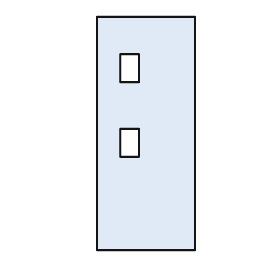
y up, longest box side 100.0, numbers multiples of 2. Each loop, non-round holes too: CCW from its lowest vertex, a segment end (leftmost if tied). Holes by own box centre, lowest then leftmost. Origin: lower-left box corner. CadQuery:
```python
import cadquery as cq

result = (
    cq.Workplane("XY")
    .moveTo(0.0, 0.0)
    .lineTo(42.0, 0.0)
    .lineTo(42.0, 100.0)
    .lineTo(0.0, 100.0)
    .close()
    .moveTo(10.0, 40.0)
    .lineTo(18.0, 40.0)
    .lineTo(18.0, 52.0)
    .lineTo(10.0, 52.0)
    .close()
    .moveTo(10.0, 72.0)
    .lineTo(18.0, 72.0)
    .lineTo(18.0, 84.0)
    .lineTo(10.0, 84.0)
    .close()
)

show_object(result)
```